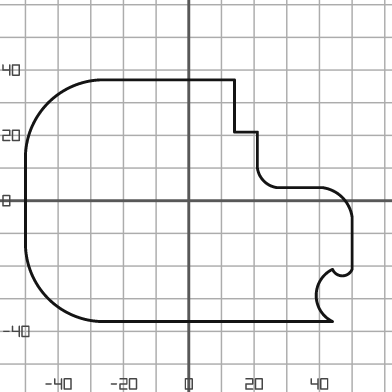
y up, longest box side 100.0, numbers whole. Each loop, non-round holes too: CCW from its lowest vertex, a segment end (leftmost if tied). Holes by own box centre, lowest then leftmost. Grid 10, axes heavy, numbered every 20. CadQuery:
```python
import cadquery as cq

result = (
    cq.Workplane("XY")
    .moveTo(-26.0, -37.0)
    .lineTo(44.0, -37.0)
    .threePointArc((39.0, -29.0), (44.0, -21.0))
    .threePointArc((47.0, -23.0), (50.0, -21.0))
    .lineTo(50.0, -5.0)
    .threePointArc((47.0, 1.0), (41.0, 4.0))
    .lineTo(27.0, 4.0)
    .threePointArc((23.0, 6.0), (21.0, 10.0))
    .lineTo(21.0, 21.0)
    .lineTo(14.0, 21.0)
    .lineTo(14.0, 37.0)
    .lineTo(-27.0, 37.0)
    .threePointArc((-43.0, 30.0), (-50.0, 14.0))
    .lineTo(-50.0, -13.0)
    .threePointArc((-43.0, -30.0), (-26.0, -37.0))
    .close()
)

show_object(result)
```